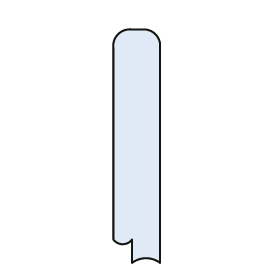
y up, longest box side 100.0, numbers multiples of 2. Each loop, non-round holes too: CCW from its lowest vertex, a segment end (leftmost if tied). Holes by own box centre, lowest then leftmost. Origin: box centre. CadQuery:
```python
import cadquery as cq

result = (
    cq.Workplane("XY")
    .moveTo(-2.0, -50.0)
    .threePointArc((4.0, -48.0), (10.0, -50.0))
    .lineTo(10.0, 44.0)
    .threePointArc((8.0, 48.0), (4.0, 50.0))
    .lineTo(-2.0, 50.0)
    .threePointArc((-8.0, 48.0), (-10.0, 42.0))
    .lineTo(-10.0, -40.0)
    .threePointArc((-6.0, -42.0), (-2.0, -40.0))
    .close()
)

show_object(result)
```